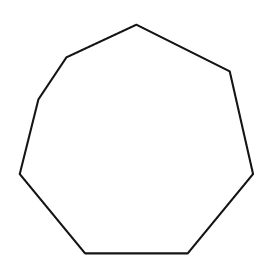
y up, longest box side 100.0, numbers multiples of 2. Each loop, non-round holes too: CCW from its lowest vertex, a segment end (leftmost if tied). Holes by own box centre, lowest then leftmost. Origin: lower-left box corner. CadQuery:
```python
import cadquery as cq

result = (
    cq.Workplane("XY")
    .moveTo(28.0, 0.0)
    .lineTo(72.0, 0.0)
    .lineTo(100.0, 34.0)
    .lineTo(90.0, 78.0)
    .lineTo(50.0, 98.0)
    .lineTo(20.0, 84.0)
    .lineTo(8.0, 66.0)
    .lineTo(0.0, 34.0)
    .close()
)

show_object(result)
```